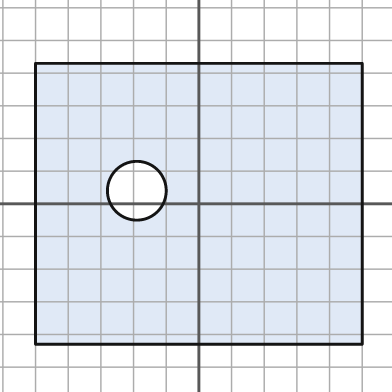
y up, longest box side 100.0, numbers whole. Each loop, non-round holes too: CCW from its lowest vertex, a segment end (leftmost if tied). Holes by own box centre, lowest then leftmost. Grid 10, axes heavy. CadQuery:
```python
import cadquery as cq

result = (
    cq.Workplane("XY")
    .moveTo(-50.0, -43.0)
    .lineTo(50.0, -43.0)
    .lineTo(50.0, 43.0)
    .lineTo(-50.0, 43.0)
    .close()
    .moveTo(-19.0, 4.0)
    .circle(9.0)
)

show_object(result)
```